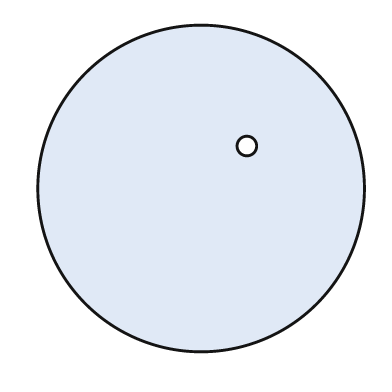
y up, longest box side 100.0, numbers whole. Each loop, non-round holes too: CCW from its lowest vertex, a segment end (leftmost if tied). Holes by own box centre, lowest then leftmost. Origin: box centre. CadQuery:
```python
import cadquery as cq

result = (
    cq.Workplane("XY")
    .moveTo(0.0, 0.0)
    .circle(50.0)
    .moveTo(14.0, 13.0)
    .circle(3.0)
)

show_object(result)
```